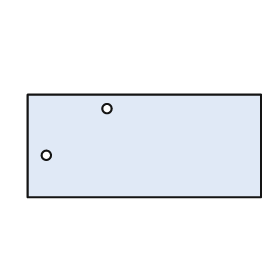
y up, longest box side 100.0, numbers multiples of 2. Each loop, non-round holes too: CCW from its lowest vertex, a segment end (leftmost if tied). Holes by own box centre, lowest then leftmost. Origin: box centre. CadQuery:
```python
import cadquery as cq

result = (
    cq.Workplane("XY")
    .moveTo(-50.0, -22.0)
    .lineTo(50.0, -22.0)
    .lineTo(50.0, 22.0)
    .lineTo(-50.0, 22.0)
    .close()
    .moveTo(-42.0, -4.0)
    .circle(2.0)
    .moveTo(-16.0, 16.0)
    .circle(2.0)
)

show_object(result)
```